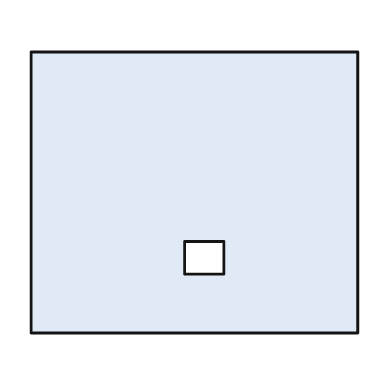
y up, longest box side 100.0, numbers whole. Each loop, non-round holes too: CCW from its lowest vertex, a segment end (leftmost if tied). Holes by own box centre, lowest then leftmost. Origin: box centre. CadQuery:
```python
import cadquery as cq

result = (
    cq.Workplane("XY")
    .moveTo(-50.0, -43.0)
    .lineTo(50.0, -43.0)
    .lineTo(50.0, 43.0)
    .lineTo(-50.0, 43.0)
    .close()
    .moveTo(-3.0, -25.0)
    .lineTo(9.0, -25.0)
    .lineTo(9.0, -15.0)
    .lineTo(-3.0, -15.0)
    .close()
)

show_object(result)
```